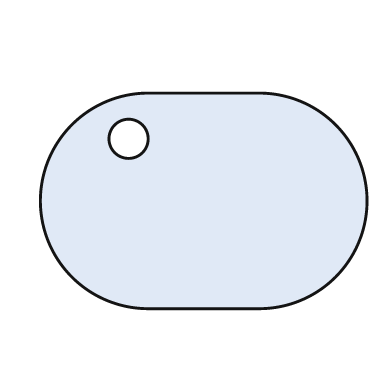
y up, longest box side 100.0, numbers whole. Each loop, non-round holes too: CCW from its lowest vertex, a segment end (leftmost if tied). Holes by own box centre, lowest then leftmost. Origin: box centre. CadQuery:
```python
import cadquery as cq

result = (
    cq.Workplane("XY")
    .moveTo(-17.0, -33.0)
    .lineTo(17.0, -33.0)
    .threePointArc((50.0, 0.0), (17.0, 33.0))
    .lineTo(-17.0, 33.0)
    .threePointArc((-50.0, 0.0), (-17.0, -33.0))
    .close()
    .moveTo(-23.0, 19.0)
    .circle(6.0)
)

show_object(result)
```